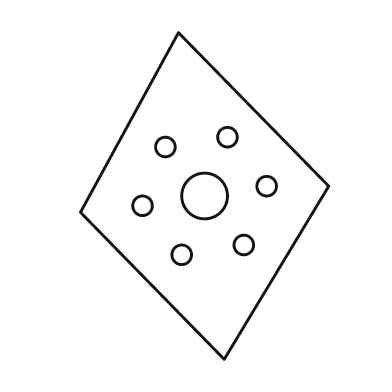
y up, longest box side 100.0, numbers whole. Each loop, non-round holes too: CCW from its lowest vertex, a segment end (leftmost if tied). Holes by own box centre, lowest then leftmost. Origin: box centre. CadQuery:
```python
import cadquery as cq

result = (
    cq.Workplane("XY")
    .moveTo(6.0, -50.0)
    .lineTo(38.0, 3.0)
    .lineTo(-8.0, 50.0)
    .lineTo(-38.0, -5.0)
    .close()
    .moveTo(-7.0, -18.0)
    .circle(3.0)
    .moveTo(12.0, -15.0)
    .circle(3.0)
    .moveTo(-19.0, -3.0)
    .circle(3.0)
    .moveTo(0.0, 0.0)
    .circle(7.0)
    .moveTo(19.0, 3.0)
    .circle(3.0)
    .moveTo(-12.0, 15.0)
    .circle(3.0)
    .moveTo(7.0, 18.0)
    .circle(3.0)
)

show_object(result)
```